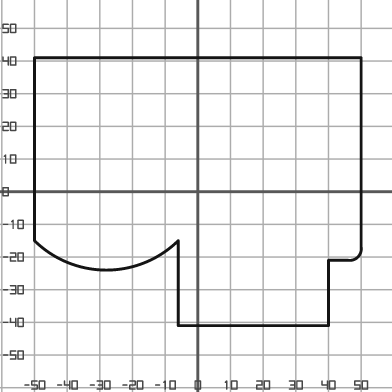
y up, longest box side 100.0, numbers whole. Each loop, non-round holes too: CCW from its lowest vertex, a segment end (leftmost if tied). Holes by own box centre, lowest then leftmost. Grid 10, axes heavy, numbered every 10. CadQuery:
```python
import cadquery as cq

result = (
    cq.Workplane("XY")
    .moveTo(-6.0, -41.0)
    .lineTo(40.0, -41.0)
    .lineTo(40.0, -21.0)
    .lineTo(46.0, -21.0)
    .threePointArc((49.0, -20.0), (50.0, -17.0))
    .lineTo(50.0, 41.0)
    .lineTo(-50.0, 41.0)
    .lineTo(-50.0, -15.0)
    .threePointArc((-28.0, -24.0), (-6.0, -15.0))
    .close()
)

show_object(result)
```